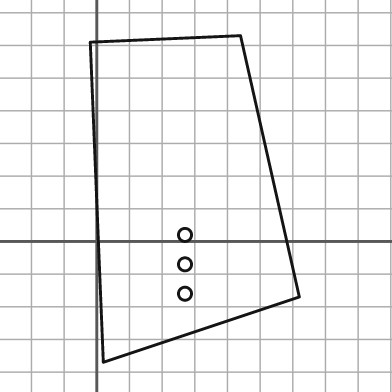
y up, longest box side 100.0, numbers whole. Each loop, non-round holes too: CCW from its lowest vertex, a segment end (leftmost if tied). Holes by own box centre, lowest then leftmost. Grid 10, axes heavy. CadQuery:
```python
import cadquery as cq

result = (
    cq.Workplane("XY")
    .moveTo(2.0, -37.0)
    .lineTo(62.0, -17.0)
    .lineTo(44.0, 63.0)
    .lineTo(-2.0, 61.0)
    .close()
    .moveTo(27.0, -16.0)
    .circle(2.0)
    .moveTo(27.0, -7.0)
    .circle(2.0)
    .moveTo(27.0, 2.0)
    .circle(2.0)
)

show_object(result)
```